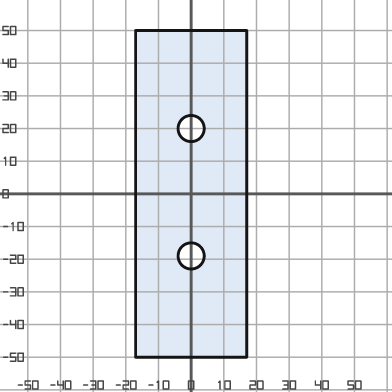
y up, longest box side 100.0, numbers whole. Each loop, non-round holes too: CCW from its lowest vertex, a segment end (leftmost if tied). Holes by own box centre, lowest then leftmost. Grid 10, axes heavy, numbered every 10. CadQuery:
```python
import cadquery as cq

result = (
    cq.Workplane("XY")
    .moveTo(-17.0, -50.0)
    .lineTo(17.0, -50.0)
    .lineTo(17.0, 50.0)
    .lineTo(-17.0, 50.0)
    .close()
    .moveTo(0.0, -19.0)
    .circle(4.0)
    .moveTo(0.0, 20.0)
    .circle(4.0)
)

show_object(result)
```